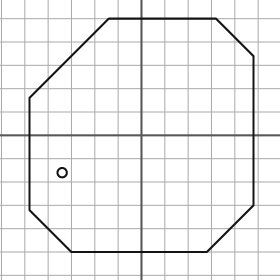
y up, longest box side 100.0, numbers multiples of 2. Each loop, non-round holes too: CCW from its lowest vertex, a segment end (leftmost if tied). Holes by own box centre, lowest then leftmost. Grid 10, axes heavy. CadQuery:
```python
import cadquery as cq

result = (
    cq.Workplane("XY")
    .moveTo(-30.0, -50.0)
    .lineTo(28.0, -50.0)
    .lineTo(48.0, -30.0)
    .lineTo(48.0, 34.0)
    .lineTo(32.0, 50.0)
    .lineTo(-14.0, 50.0)
    .lineTo(-48.0, 16.0)
    .lineTo(-48.0, -32.0)
    .close()
    .moveTo(-34.0, -16.0)
    .circle(2.0)
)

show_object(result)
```